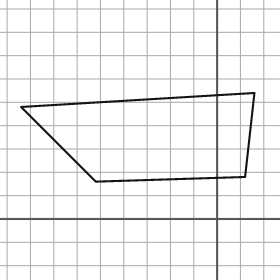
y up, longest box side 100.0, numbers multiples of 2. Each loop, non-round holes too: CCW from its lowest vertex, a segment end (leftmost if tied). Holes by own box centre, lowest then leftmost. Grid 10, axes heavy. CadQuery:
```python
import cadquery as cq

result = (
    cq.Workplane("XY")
    .moveTo(-52.0, 16.0)
    .lineTo(12.0, 18.0)
    .lineTo(16.0, 54.0)
    .lineTo(-84.0, 48.0)
    .close()
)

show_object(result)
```